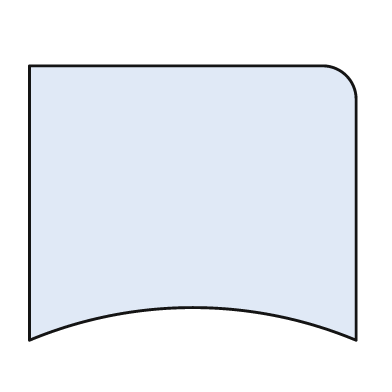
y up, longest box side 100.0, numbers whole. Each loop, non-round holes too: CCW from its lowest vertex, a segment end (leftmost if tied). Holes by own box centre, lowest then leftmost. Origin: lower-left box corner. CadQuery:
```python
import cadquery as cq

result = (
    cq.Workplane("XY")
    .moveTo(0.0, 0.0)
    .threePointArc((50.0, 10.0), (100.0, 0.0))
    .lineTo(100.0, 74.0)
    .threePointArc((97.0, 81.0), (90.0, 84.0))
    .lineTo(0.0, 84.0)
    .close()
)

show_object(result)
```